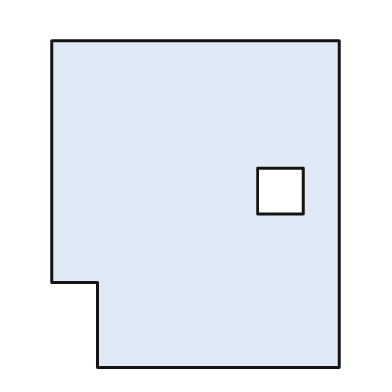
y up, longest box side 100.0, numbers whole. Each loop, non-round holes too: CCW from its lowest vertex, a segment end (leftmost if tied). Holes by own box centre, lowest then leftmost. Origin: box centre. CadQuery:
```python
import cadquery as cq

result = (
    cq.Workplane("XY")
    .moveTo(-30.0, -50.0)
    .lineTo(44.0, -50.0)
    .lineTo(44.0, 50.0)
    .lineTo(-44.0, 50.0)
    .lineTo(-44.0, -24.0)
    .lineTo(-30.0, -24.0)
    .close()
    .moveTo(19.0, -3.0)
    .lineTo(33.0, -3.0)
    .lineTo(33.0, 11.0)
    .lineTo(19.0, 11.0)
    .close()
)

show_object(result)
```